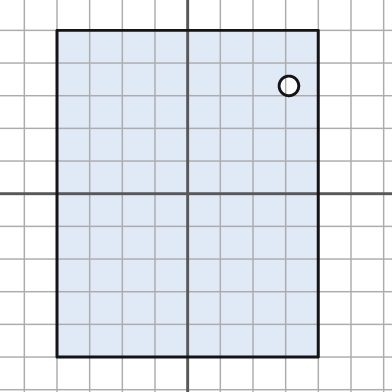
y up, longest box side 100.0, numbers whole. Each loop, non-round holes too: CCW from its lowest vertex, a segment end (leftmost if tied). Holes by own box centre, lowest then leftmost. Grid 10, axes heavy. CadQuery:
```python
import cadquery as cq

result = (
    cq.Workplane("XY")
    .moveTo(-40.0, -50.0)
    .lineTo(40.0, -50.0)
    .lineTo(40.0, 50.0)
    .lineTo(-40.0, 50.0)
    .close()
    .moveTo(31.0, 33.0)
    .circle(3.0)
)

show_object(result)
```